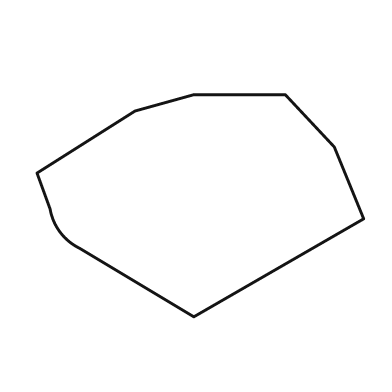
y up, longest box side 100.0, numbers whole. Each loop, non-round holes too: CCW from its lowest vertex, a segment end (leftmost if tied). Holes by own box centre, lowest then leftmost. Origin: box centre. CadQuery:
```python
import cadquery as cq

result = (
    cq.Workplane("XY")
    .moveTo(-2.0, -34.0)
    .lineTo(50.0, -4.0)
    .lineTo(41.0, 18.0)
    .lineTo(26.0, 34.0)
    .lineTo(-2.0, 34.0)
    .lineTo(-20.0, 29.0)
    .lineTo(-50.0, 10.0)
    .lineTo(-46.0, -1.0)
    .threePointArc((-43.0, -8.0), (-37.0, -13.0))
    .close()
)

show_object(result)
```